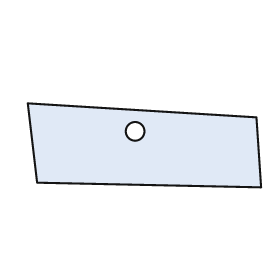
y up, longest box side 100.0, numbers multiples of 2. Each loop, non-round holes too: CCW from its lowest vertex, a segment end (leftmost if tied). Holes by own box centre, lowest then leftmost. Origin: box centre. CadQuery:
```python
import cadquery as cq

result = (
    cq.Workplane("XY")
    .moveTo(50.0, -18.0)
    .lineTo(48.0, 12.0)
    .lineTo(-50.0, 18.0)
    .lineTo(-46.0, -16.0)
    .close()
    .moveTo(-4.0, 6.0)
    .circle(4.0)
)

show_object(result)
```